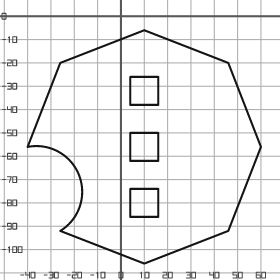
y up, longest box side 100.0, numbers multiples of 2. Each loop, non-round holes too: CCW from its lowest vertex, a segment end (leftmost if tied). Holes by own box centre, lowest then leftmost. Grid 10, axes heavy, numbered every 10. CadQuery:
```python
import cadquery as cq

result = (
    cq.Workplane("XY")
    .moveTo(10.0, -106.0)
    .lineTo(46.0, -92.0)
    .lineTo(60.0, -56.0)
    .lineTo(46.0, -20.0)
    .lineTo(10.0, -6.0)
    .lineTo(-26.0, -20.0)
    .lineTo(-40.0, -56.0)
    .threePointArc((-18.0, -68.0), (-26.0, -92.0))
    .close()
    .moveTo(4.0, -86.0)
    .lineTo(16.0, -86.0)
    .lineTo(16.0, -74.0)
    .lineTo(4.0, -74.0)
    .close()
    .moveTo(4.0, -62.0)
    .lineTo(16.0, -62.0)
    .lineTo(16.0, -50.0)
    .lineTo(4.0, -50.0)
    .close()
    .moveTo(4.0, -38.0)
    .lineTo(16.0, -38.0)
    .lineTo(16.0, -26.0)
    .lineTo(4.0, -26.0)
    .close()
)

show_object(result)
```